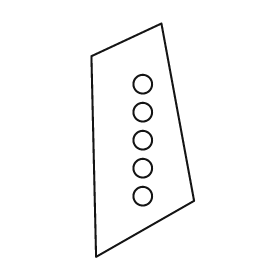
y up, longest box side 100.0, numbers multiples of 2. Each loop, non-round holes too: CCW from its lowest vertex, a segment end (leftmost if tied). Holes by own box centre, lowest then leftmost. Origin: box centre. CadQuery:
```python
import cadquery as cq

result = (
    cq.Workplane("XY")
    .moveTo(-20.0, -50.0)
    .lineTo(22.0, -26.0)
    .lineTo(8.0, 50.0)
    .lineTo(-22.0, 36.0)
    .close()
    .moveTo(0.0, -24.0)
    .circle(4.0)
    .moveTo(0.0, -12.0)
    .circle(4.0)
    .moveTo(0.0, 0.0)
    .circle(4.0)
    .moveTo(0.0, 12.0)
    .circle(4.0)
    .moveTo(0.0, 24.0)
    .circle(4.0)
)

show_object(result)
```